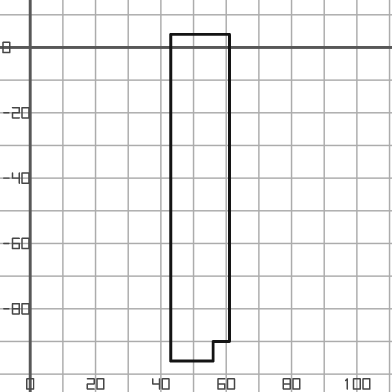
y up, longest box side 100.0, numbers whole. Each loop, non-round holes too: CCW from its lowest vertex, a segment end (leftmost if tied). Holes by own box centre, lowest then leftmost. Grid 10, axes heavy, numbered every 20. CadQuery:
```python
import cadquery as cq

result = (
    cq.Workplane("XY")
    .moveTo(43.0, -96.0)
    .lineTo(56.0, -96.0)
    .lineTo(56.0, -90.0)
    .lineTo(61.0, -90.0)
    .lineTo(61.0, 4.0)
    .lineTo(43.0, 4.0)
    .close()
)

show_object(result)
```